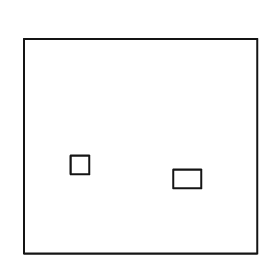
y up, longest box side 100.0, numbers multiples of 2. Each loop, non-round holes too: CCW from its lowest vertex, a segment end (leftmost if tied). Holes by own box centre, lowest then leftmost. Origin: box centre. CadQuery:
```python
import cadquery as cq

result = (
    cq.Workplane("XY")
    .moveTo(-50.0, -46.0)
    .lineTo(50.0, -46.0)
    .lineTo(50.0, 46.0)
    .lineTo(-50.0, 46.0)
    .close()
    .moveTo(14.0, -18.0)
    .lineTo(26.0, -18.0)
    .lineTo(26.0, -10.0)
    .lineTo(14.0, -10.0)
    .close()
    .moveTo(-30.0, -12.0)
    .lineTo(-22.0, -12.0)
    .lineTo(-22.0, -4.0)
    .lineTo(-30.0, -4.0)
    .close()
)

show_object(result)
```